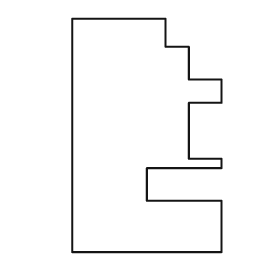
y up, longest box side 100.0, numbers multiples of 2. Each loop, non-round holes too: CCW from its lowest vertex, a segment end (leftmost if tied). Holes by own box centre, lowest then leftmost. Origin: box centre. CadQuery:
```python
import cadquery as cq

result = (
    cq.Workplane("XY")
    .moveTo(-32.0, -50.0)
    .lineTo(32.0, -50.0)
    .lineTo(32.0, -28.0)
    .lineTo(0.0, -28.0)
    .lineTo(0.0, -14.0)
    .lineTo(32.0, -14.0)
    .lineTo(32.0, -10.0)
    .lineTo(18.0, -10.0)
    .lineTo(18.0, 14.0)
    .lineTo(32.0, 14.0)
    .lineTo(32.0, 24.0)
    .lineTo(18.0, 24.0)
    .lineTo(18.0, 38.0)
    .lineTo(8.0, 38.0)
    .lineTo(8.0, 50.0)
    .lineTo(-32.0, 50.0)
    .close()
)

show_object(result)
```